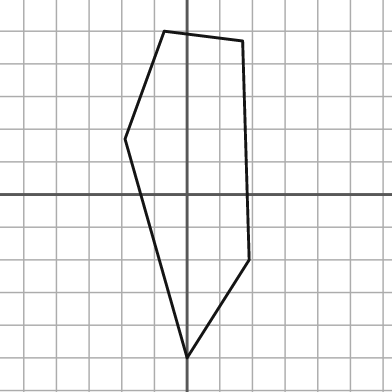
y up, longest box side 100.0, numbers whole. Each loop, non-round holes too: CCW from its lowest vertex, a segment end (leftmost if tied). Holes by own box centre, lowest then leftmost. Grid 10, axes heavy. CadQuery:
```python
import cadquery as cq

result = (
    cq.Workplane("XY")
    .moveTo(0.0, -50.0)
    .lineTo(19.0, -20.0)
    .lineTo(17.0, 47.0)
    .lineTo(-7.0, 50.0)
    .lineTo(-19.0, 17.0)
    .close()
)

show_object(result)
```